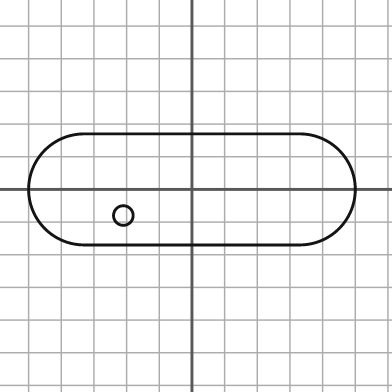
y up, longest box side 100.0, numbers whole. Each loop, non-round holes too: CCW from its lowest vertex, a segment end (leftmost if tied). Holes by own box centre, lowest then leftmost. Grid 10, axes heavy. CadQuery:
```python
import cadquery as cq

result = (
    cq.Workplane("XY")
    .moveTo(-33.0, -17.0)
    .lineTo(33.0, -17.0)
    .threePointArc((50.0, 0.0), (33.0, 17.0))
    .lineTo(-33.0, 17.0)
    .threePointArc((-50.0, 0.0), (-33.0, -17.0))
    .close()
    .moveTo(-21.0, -8.0)
    .circle(3.0)
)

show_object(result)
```